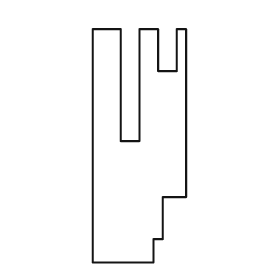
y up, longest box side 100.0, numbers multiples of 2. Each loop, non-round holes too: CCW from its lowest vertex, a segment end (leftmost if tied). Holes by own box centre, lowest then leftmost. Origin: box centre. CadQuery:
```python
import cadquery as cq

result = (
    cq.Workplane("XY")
    .moveTo(-20.0, -50.0)
    .lineTo(6.0, -50.0)
    .lineTo(6.0, -40.0)
    .lineTo(10.0, -40.0)
    .lineTo(10.0, -22.0)
    .lineTo(20.0, -22.0)
    .lineTo(20.0, 50.0)
    .lineTo(16.0, 50.0)
    .lineTo(16.0, 32.0)
    .lineTo(8.0, 32.0)
    .lineTo(8.0, 50.0)
    .lineTo(0.0, 50.0)
    .lineTo(0.0, 2.0)
    .lineTo(-8.0, 2.0)
    .lineTo(-8.0, 50.0)
    .lineTo(-20.0, 50.0)
    .close()
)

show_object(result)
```